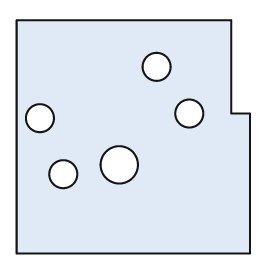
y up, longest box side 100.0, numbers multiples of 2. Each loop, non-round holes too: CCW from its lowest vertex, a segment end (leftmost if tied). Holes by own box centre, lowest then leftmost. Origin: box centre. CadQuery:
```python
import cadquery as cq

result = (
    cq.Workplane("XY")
    .moveTo(-50.0, -50.0)
    .lineTo(50.0, -50.0)
    .lineTo(50.0, 10.0)
    .lineTo(42.0, 10.0)
    .lineTo(42.0, 50.0)
    .lineTo(-50.0, 50.0)
    .close()
    .moveTo(-30.0, -16.0)
    .circle(6.0)
    .moveTo(-6.0, -12.0)
    .circle(8.0)
    .moveTo(-40.0, 8.0)
    .circle(6.0)
    .moveTo(24.0, 10.0)
    .circle(6.0)
    .moveTo(10.0, 30.0)
    .circle(6.0)
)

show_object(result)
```